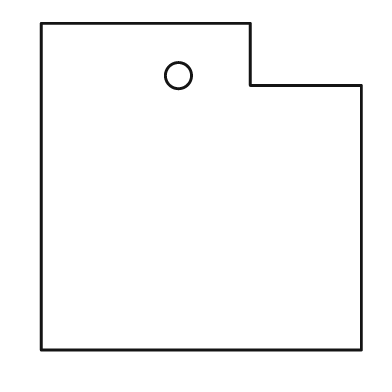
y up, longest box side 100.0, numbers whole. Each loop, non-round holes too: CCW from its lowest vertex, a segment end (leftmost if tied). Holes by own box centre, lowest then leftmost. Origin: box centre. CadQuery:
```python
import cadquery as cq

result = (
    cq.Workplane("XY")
    .moveTo(-49.0, -50.0)
    .lineTo(49.0, -50.0)
    .lineTo(49.0, 31.0)
    .lineTo(15.0, 31.0)
    .lineTo(15.0, 50.0)
    .lineTo(-49.0, 50.0)
    .close()
    .moveTo(-7.0, 34.0)
    .circle(4.0)
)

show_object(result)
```